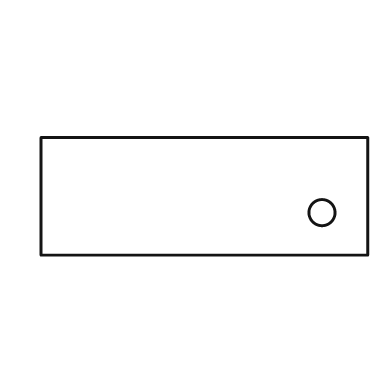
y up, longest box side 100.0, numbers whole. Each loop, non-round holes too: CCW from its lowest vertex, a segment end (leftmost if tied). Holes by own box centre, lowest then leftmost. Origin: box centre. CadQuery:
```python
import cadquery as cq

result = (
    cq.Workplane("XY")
    .moveTo(-50.0, -18.0)
    .lineTo(50.0, -18.0)
    .lineTo(50.0, 18.0)
    .lineTo(-50.0, 18.0)
    .close()
    .moveTo(36.0, -5.0)
    .circle(4.0)
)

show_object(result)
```